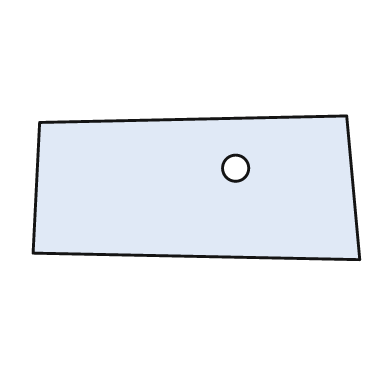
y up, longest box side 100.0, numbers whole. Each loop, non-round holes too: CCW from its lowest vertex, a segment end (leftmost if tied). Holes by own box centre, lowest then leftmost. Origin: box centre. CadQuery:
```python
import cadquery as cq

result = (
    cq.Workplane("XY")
    .moveTo(50.0, -22.0)
    .lineTo(46.0, 22.0)
    .lineTo(-48.0, 20.0)
    .lineTo(-50.0, -20.0)
    .close()
    .moveTo(12.0, 6.0)
    .circle(4.0)
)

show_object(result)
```